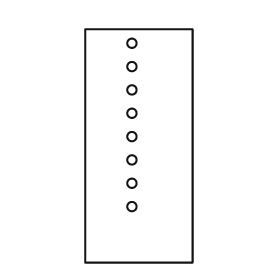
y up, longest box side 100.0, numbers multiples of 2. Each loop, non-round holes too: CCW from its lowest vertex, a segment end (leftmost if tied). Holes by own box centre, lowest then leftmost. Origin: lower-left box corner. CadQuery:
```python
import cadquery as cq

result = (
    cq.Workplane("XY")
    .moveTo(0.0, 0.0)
    .lineTo(46.0, 0.0)
    .lineTo(46.0, 100.0)
    .lineTo(0.0, 100.0)
    .close()
    .moveTo(20.0, 24.0)
    .circle(2.0)
    .moveTo(20.0, 34.0)
    .circle(2.0)
    .moveTo(20.0, 44.0)
    .circle(2.0)
    .moveTo(20.0, 54.0)
    .circle(2.0)
    .moveTo(20.0, 64.0)
    .circle(2.0)
    .moveTo(20.0, 74.0)
    .circle(2.0)
    .moveTo(20.0, 84.0)
    .circle(2.0)
    .moveTo(20.0, 94.0)
    .circle(2.0)
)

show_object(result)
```